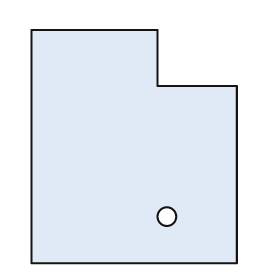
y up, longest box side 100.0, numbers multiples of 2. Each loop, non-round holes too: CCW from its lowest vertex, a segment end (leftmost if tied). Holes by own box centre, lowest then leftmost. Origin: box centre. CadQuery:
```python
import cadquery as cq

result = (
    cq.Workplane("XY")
    .moveTo(-44.0, -50.0)
    .lineTo(44.0, -50.0)
    .lineTo(44.0, 26.0)
    .lineTo(10.0, 26.0)
    .lineTo(10.0, 50.0)
    .lineTo(-44.0, 50.0)
    .close()
    .moveTo(14.0, -30.0)
    .circle(4.0)
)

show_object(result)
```